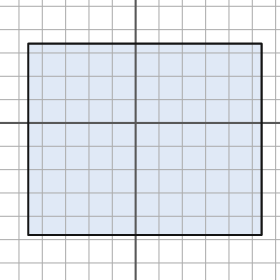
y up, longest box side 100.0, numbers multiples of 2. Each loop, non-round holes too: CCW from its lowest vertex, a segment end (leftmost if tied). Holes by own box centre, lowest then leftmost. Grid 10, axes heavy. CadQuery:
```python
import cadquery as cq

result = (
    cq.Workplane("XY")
    .moveTo(-46.0, -48.0)
    .lineTo(54.0, -48.0)
    .lineTo(54.0, 34.0)
    .lineTo(-46.0, 34.0)
    .close()
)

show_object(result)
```